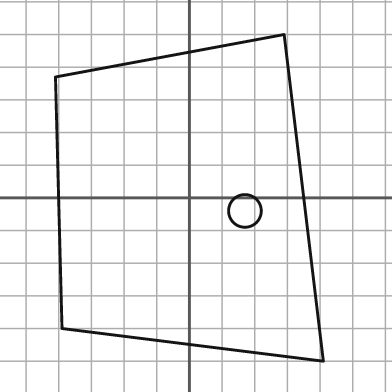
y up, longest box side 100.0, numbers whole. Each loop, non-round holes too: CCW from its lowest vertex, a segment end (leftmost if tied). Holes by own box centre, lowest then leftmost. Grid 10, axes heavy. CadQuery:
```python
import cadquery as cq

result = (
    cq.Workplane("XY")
    .moveTo(41.0, -50.0)
    .lineTo(29.0, 50.0)
    .lineTo(-41.0, 37.0)
    .lineTo(-39.0, -40.0)
    .close()
    .moveTo(17.0, -4.0)
    .circle(5.0)
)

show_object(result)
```